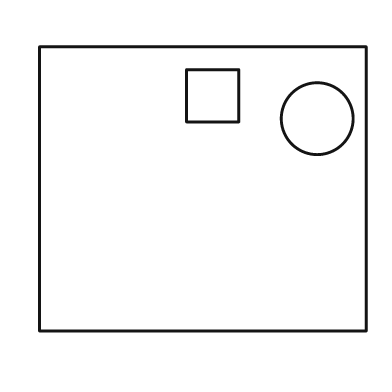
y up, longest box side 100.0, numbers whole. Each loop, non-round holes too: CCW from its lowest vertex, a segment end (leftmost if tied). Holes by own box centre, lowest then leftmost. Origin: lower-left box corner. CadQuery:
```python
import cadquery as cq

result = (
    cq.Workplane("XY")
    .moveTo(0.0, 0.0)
    .lineTo(100.0, 0.0)
    .lineTo(100.0, 87.0)
    .lineTo(0.0, 87.0)
    .close()
    .moveTo(85.0, 65.0)
    .circle(11.0)
    .moveTo(45.0, 64.0)
    .lineTo(61.0, 64.0)
    .lineTo(61.0, 80.0)
    .lineTo(45.0, 80.0)
    .close()
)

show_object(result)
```